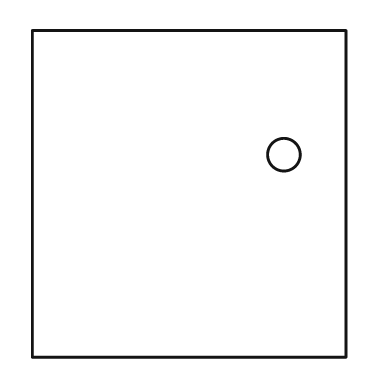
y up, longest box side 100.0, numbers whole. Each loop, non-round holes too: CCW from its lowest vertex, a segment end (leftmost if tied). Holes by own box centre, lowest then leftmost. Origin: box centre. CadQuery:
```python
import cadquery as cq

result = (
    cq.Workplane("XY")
    .moveTo(-48.0, -50.0)
    .lineTo(48.0, -50.0)
    .lineTo(48.0, 50.0)
    .lineTo(-48.0, 50.0)
    .close()
    .moveTo(29.0, 12.0)
    .circle(5.0)
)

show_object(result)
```